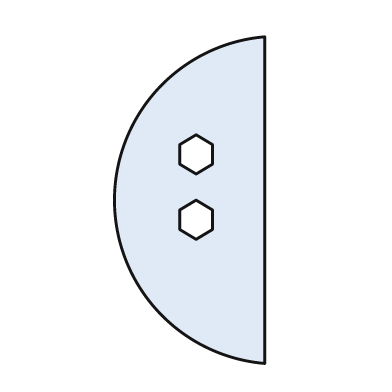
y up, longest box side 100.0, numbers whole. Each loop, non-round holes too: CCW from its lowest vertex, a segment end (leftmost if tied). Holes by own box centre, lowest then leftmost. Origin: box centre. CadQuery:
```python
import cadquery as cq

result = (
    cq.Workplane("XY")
    .moveTo(23.0, -50.0)
    .lineTo(23.0, 50.0)
    .threePointArc((-23.0, 0.0), (23.0, -50.0))
    .close()
    .moveTo(2.0, -12.0)
    .lineTo(7.0, -9.0)
    .lineTo(7.0, -3.0)
    .lineTo(2.0, 0.0)
    .lineTo(-3.0, -3.0)
    .lineTo(-3.0, -9.0)
    .close()
    .moveTo(2.0, 8.0)
    .lineTo(7.0, 11.0)
    .lineTo(7.0, 17.0)
    .lineTo(2.0, 20.0)
    .lineTo(-3.0, 17.0)
    .lineTo(-3.0, 11.0)
    .close()
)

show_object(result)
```